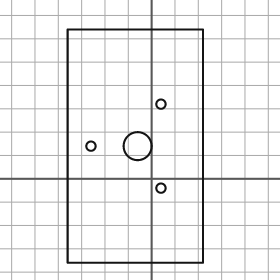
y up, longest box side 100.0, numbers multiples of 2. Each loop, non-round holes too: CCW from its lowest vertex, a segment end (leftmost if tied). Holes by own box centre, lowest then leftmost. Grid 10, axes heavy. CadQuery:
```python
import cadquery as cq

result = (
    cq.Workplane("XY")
    .moveTo(-36.0, -36.0)
    .lineTo(22.0, -36.0)
    .lineTo(22.0, 64.0)
    .lineTo(-36.0, 64.0)
    .close()
    .moveTo(4.0, -4.0)
    .circle(2.0)
    .moveTo(-26.0, 14.0)
    .circle(2.0)
    .moveTo(-6.0, 14.0)
    .circle(6.0)
    .moveTo(4.0, 32.0)
    .circle(2.0)
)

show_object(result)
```